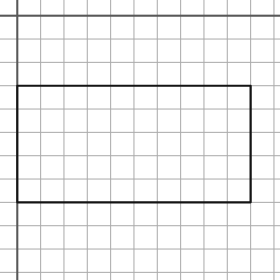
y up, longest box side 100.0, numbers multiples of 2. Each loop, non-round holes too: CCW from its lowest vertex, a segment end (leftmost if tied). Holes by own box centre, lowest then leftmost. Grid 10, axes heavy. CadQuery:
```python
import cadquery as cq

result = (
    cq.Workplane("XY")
    .moveTo(0.0, -80.0)
    .lineTo(100.0, -80.0)
    .lineTo(100.0, -30.0)
    .lineTo(0.0, -30.0)
    .close()
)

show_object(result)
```